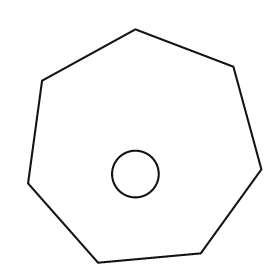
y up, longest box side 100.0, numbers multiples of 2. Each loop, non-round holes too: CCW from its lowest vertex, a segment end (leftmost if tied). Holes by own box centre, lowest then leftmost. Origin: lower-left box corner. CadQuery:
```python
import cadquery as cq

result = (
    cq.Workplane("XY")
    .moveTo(30.0, 0.0)
    .lineTo(74.0, 4.0)
    .lineTo(100.0, 40.0)
    .lineTo(88.0, 84.0)
    .lineTo(46.0, 100.0)
    .lineTo(6.0, 78.0)
    .lineTo(0.0, 34.0)
    .close()
    .moveTo(46.0, 38.0)
    .circle(10.0)
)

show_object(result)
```